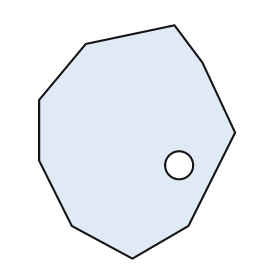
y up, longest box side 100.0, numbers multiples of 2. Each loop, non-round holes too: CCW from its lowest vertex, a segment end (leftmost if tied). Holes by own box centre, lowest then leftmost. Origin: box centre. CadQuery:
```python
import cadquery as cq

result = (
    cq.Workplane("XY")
    .moveTo(-2.0, -50.0)
    .lineTo(22.0, -36.0)
    .lineTo(42.0, 4.0)
    .lineTo(28.0, 34.0)
    .lineTo(16.0, 50.0)
    .lineTo(-22.0, 42.0)
    .lineTo(-42.0, 18.0)
    .lineTo(-42.0, -8.0)
    .lineTo(-28.0, -36.0)
    .close()
    .moveTo(18.0, -10.0)
    .circle(6.0)
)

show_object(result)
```